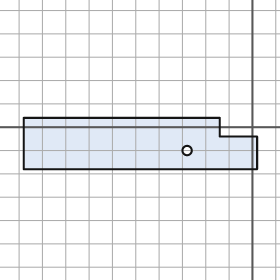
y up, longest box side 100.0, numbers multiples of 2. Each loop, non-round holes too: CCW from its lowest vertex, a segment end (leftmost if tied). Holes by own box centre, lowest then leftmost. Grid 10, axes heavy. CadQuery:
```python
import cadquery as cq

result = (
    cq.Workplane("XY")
    .moveTo(-98.0, -18.0)
    .lineTo(2.0, -18.0)
    .lineTo(2.0, -4.0)
    .lineTo(-14.0, -4.0)
    .lineTo(-14.0, 4.0)
    .lineTo(-98.0, 4.0)
    .close()
    .moveTo(-28.0, -10.0)
    .circle(2.0)
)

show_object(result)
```